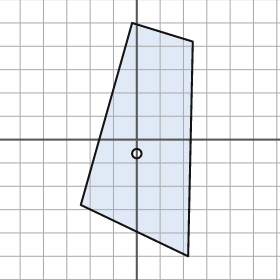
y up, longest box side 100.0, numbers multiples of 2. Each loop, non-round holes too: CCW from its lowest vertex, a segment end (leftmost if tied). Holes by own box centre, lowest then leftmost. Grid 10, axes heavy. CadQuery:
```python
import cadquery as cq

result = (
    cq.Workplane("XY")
    .moveTo(22.0, -50.0)
    .lineTo(24.0, 42.0)
    .lineTo(-2.0, 50.0)
    .lineTo(-24.0, -28.0)
    .close()
    .moveTo(0.0, -6.0)
    .circle(2.0)
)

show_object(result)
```